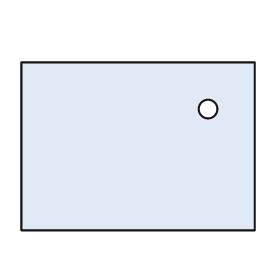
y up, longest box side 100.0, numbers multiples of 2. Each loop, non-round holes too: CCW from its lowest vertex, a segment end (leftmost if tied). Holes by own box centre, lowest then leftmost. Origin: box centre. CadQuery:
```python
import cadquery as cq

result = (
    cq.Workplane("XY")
    .moveTo(-50.0, -36.0)
    .lineTo(50.0, -36.0)
    .lineTo(50.0, 36.0)
    .lineTo(-50.0, 36.0)
    .close()
    .moveTo(30.0, 16.0)
    .circle(4.0)
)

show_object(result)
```